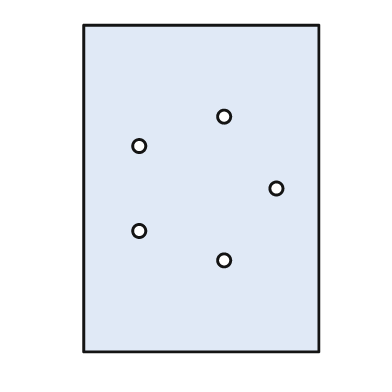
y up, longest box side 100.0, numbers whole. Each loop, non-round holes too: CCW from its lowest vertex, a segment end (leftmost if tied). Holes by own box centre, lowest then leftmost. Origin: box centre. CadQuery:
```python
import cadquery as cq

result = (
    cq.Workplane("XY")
    .moveTo(-36.0, -50.0)
    .lineTo(36.0, -50.0)
    .lineTo(36.0, 50.0)
    .lineTo(-36.0, 50.0)
    .close()
    .moveTo(7.0, -22.0)
    .circle(2.0)
    .moveTo(-19.0, -13.0)
    .circle(2.0)
    .moveTo(23.0, 0.0)
    .circle(2.0)
    .moveTo(-19.0, 13.0)
    .circle(2.0)
    .moveTo(7.0, 22.0)
    .circle(2.0)
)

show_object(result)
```